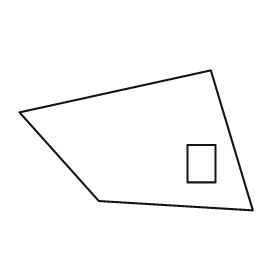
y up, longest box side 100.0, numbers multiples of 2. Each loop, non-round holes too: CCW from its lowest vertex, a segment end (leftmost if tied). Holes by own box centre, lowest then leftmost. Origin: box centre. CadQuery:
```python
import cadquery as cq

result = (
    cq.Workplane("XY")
    .moveTo(50.0, -30.0)
    .lineTo(32.0, 30.0)
    .lineTo(-50.0, 12.0)
    .lineTo(-16.0, -26.0)
    .close()
    .moveTo(22.0, -18.0)
    .lineTo(34.0, -18.0)
    .lineTo(34.0, -2.0)
    .lineTo(22.0, -2.0)
    .close()
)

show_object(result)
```